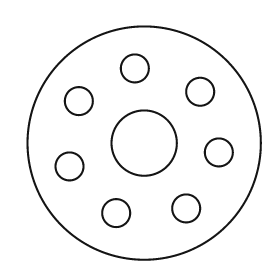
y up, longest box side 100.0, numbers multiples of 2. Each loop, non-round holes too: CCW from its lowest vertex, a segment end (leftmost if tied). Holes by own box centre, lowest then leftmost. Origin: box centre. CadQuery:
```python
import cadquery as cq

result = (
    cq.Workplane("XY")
    .moveTo(0.0, 0.0)
    .circle(50.0)
    .moveTo(-12.0, -30.0)
    .circle(6.0)
    .moveTo(18.0, -28.0)
    .circle(6.0)
    .moveTo(-32.0, -10.0)
    .circle(6.0)
    .moveTo(32.0, -4.0)
    .circle(6.0)
    .moveTo(0.0, 0.0)
    .circle(14.0)
    .moveTo(-28.0, 18.0)
    .circle(6.0)
    .moveTo(24.0, 22.0)
    .circle(6.0)
    .moveTo(-4.0, 32.0)
    .circle(6.0)
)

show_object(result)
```